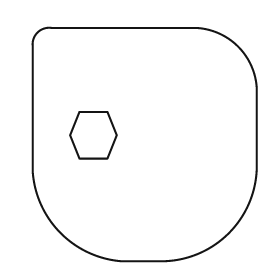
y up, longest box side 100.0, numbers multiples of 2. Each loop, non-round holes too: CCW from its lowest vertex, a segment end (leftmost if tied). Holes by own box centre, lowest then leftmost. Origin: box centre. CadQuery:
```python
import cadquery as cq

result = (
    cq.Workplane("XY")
    .moveTo(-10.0, -50.0)
    .lineTo(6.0, -50.0)
    .threePointArc((36.0, -38.0), (48.0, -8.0))
    .lineTo(48.0, 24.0)
    .threePointArc((40.0, 42.0), (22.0, 50.0))
    .lineTo(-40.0, 50.0)
    .threePointArc((-46.0, 48.0), (-48.0, 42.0))
    .lineTo(-48.0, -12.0)
    .threePointArc((-36.0, -38.0), (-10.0, -50.0))
    .close()
    .moveTo(-28.0, -6.0)
    .lineTo(-16.0, -6.0)
    .lineTo(-12.0, 4.0)
    .lineTo(-16.0, 14.0)
    .lineTo(-28.0, 14.0)
    .lineTo(-32.0, 4.0)
    .close()
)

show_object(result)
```